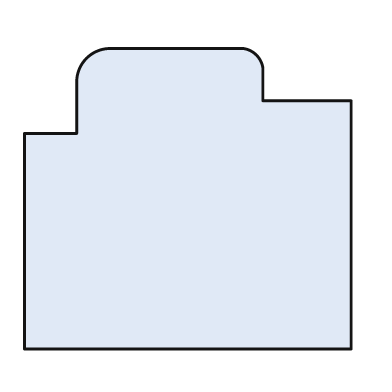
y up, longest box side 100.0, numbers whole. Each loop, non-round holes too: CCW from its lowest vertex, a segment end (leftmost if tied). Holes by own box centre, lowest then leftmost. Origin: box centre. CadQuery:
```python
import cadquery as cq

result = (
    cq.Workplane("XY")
    .moveTo(-50.0, -46.0)
    .lineTo(50.0, -46.0)
    .lineTo(50.0, 30.0)
    .lineTo(23.0, 30.0)
    .lineTo(23.0, 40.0)
    .threePointArc((21.0, 44.0), (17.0, 46.0))
    .lineTo(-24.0, 46.0)
    .threePointArc((-31.0, 43.0), (-34.0, 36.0))
    .lineTo(-34.0, 20.0)
    .lineTo(-50.0, 20.0)
    .close()
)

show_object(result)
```